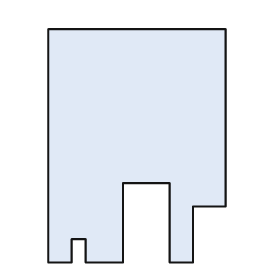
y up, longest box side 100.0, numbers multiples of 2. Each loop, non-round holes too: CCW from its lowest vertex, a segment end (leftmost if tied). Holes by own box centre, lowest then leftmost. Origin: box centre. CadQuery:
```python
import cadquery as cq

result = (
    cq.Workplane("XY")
    .moveTo(-38.0, -50.0)
    .lineTo(-28.0, -50.0)
    .lineTo(-28.0, -40.0)
    .lineTo(-22.0, -40.0)
    .lineTo(-22.0, -50.0)
    .lineTo(-6.0, -50.0)
    .lineTo(-6.0, -16.0)
    .lineTo(14.0, -16.0)
    .lineTo(14.0, -50.0)
    .lineTo(24.0, -50.0)
    .lineTo(24.0, -26.0)
    .lineTo(38.0, -26.0)
    .lineTo(38.0, 50.0)
    .lineTo(-38.0, 50.0)
    .close()
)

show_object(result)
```